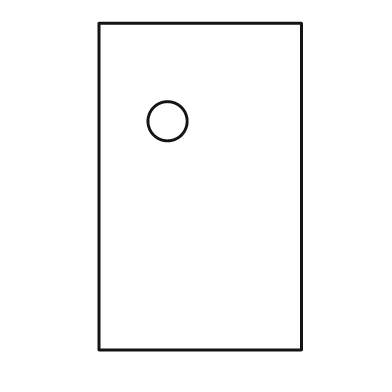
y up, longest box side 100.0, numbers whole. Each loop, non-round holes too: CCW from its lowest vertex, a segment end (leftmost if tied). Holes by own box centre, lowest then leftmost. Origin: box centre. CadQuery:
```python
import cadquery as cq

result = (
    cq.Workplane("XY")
    .moveTo(-31.0, -50.0)
    .lineTo(31.0, -50.0)
    .lineTo(31.0, 50.0)
    .lineTo(-31.0, 50.0)
    .close()
    .moveTo(-10.0, 20.0)
    .circle(6.0)
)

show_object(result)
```